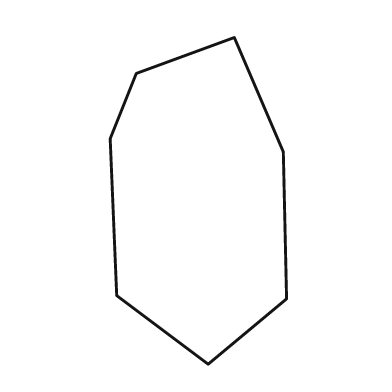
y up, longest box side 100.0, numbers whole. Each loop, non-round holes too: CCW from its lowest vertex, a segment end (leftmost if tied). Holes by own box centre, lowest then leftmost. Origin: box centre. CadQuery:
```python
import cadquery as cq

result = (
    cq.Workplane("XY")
    .moveTo(3.0, -50.0)
    .lineTo(27.0, -30.0)
    .lineTo(26.0, 15.0)
    .lineTo(11.0, 50.0)
    .lineTo(-19.0, 39.0)
    .lineTo(-27.0, 19.0)
    .lineTo(-25.0, -29.0)
    .close()
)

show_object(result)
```